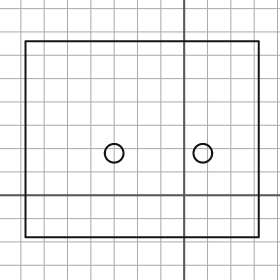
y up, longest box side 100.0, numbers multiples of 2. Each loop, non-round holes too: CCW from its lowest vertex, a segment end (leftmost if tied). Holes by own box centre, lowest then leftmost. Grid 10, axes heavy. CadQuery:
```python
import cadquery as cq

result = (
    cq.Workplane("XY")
    .moveTo(-68.0, -18.0)
    .lineTo(32.0, -18.0)
    .lineTo(32.0, 66.0)
    .lineTo(-68.0, 66.0)
    .close()
    .moveTo(-30.0, 18.0)
    .circle(4.0)
    .moveTo(8.0, 18.0)
    .circle(4.0)
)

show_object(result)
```